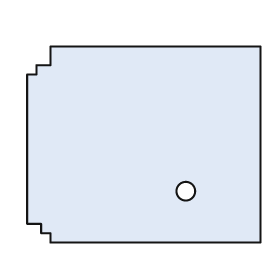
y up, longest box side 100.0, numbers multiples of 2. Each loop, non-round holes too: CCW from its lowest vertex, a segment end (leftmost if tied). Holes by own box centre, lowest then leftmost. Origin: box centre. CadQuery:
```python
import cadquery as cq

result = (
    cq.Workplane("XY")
    .moveTo(-40.0, -42.0)
    .lineTo(50.0, -42.0)
    .lineTo(50.0, 42.0)
    .lineTo(-40.0, 42.0)
    .lineTo(-40.0, 34.0)
    .lineTo(-46.0, 34.0)
    .lineTo(-46.0, 30.0)
    .lineTo(-50.0, 30.0)
    .lineTo(-50.0, -34.0)
    .lineTo(-44.0, -34.0)
    .lineTo(-44.0, -38.0)
    .lineTo(-40.0, -38.0)
    .close()
    .moveTo(18.0, -20.0)
    .circle(4.0)
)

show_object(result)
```